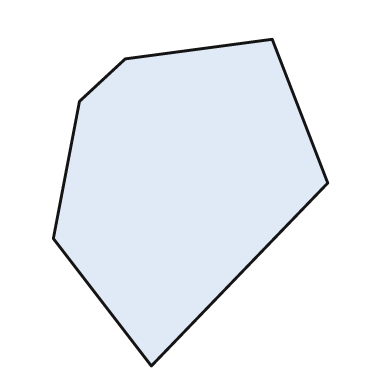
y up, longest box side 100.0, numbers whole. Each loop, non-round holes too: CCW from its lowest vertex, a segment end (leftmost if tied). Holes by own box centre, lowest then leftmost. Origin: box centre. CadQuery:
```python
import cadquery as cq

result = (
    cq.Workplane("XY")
    .moveTo(-12.0, -50.0)
    .lineTo(42.0, 6.0)
    .lineTo(25.0, 50.0)
    .lineTo(-20.0, 44.0)
    .lineTo(-34.0, 31.0)
    .lineTo(-42.0, -11.0)
    .close()
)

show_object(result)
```